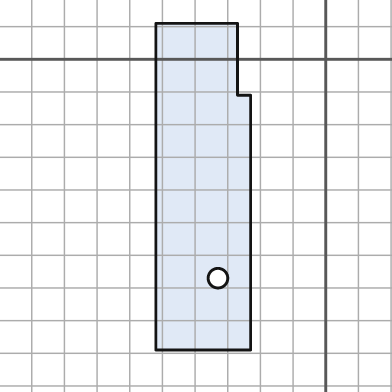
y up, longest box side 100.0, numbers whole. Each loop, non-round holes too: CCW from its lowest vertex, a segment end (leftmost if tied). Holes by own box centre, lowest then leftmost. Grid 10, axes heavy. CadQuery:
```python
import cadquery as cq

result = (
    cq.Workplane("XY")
    .moveTo(-52.0, -89.0)
    .lineTo(-23.0, -89.0)
    .lineTo(-23.0, -11.0)
    .lineTo(-27.0, -11.0)
    .lineTo(-27.0, 11.0)
    .lineTo(-52.0, 11.0)
    .close()
    .moveTo(-33.0, -67.0)
    .circle(3.0)
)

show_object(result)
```